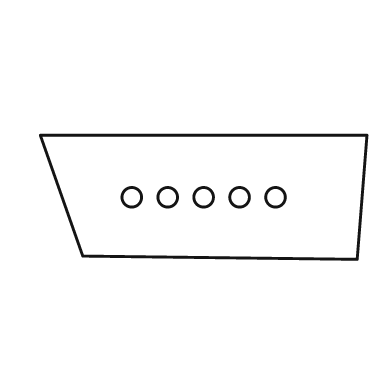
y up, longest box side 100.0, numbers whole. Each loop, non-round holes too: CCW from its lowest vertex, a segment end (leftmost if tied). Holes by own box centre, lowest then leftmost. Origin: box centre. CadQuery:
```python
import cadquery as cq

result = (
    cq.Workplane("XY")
    .moveTo(47.0, -19.0)
    .lineTo(50.0, 19.0)
    .lineTo(-50.0, 19.0)
    .lineTo(-37.0, -18.0)
    .close()
    .moveTo(-22.0, 0.0)
    .circle(3.0)
    .moveTo(-11.0, 0.0)
    .circle(3.0)
    .moveTo(0.0, 0.0)
    .circle(3.0)
    .moveTo(11.0, 0.0)
    .circle(3.0)
    .moveTo(22.0, 0.0)
    .circle(3.0)
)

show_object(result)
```